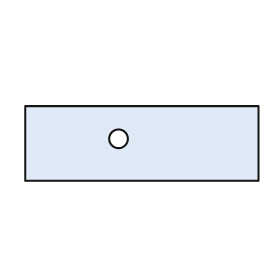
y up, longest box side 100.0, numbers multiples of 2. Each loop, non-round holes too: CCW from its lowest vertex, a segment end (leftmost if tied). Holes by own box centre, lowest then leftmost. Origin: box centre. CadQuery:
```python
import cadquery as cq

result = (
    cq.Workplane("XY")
    .moveTo(-50.0, -16.0)
    .lineTo(50.0, -16.0)
    .lineTo(50.0, 16.0)
    .lineTo(-50.0, 16.0)
    .close()
    .moveTo(-10.0, 2.0)
    .circle(4.0)
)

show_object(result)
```